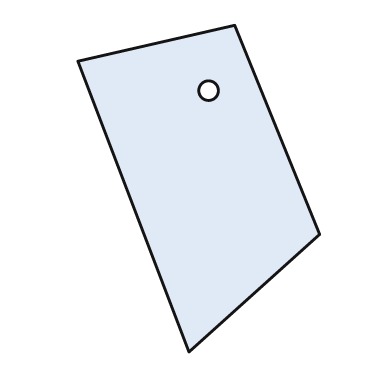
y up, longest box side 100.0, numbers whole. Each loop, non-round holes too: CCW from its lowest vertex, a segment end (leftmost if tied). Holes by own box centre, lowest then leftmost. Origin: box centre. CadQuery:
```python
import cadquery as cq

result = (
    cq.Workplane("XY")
    .moveTo(-3.0, -50.0)
    .lineTo(37.0, -14.0)
    .lineTo(11.0, 50.0)
    .lineTo(-37.0, 39.0)
    .close()
    .moveTo(3.0, 30.0)
    .circle(3.0)
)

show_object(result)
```